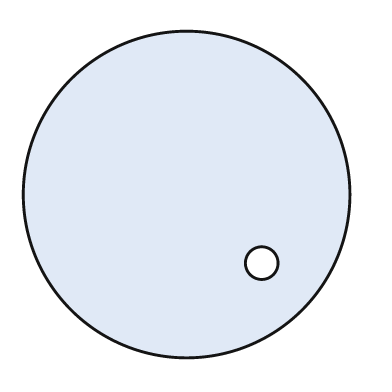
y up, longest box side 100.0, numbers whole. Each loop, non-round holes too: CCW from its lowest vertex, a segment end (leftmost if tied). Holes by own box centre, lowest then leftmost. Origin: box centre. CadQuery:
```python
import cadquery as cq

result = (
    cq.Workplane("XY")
    .moveTo(0.0, 0.0)
    .circle(50.0)
    .moveTo(23.0, -21.0)
    .circle(5.0)
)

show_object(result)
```